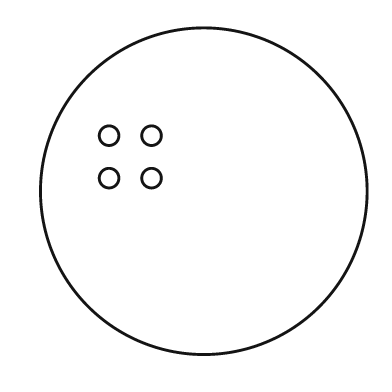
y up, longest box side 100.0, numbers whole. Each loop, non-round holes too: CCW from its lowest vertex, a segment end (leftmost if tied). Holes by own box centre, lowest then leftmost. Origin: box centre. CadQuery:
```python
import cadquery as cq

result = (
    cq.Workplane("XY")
    .moveTo(0.0, 0.0)
    .circle(50.0)
    .moveTo(-29.0, 4.0)
    .circle(3.0)
    .moveTo(-16.0, 4.0)
    .circle(3.0)
    .moveTo(-29.0, 17.0)
    .circle(3.0)
    .moveTo(-16.0, 17.0)
    .circle(3.0)
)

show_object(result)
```